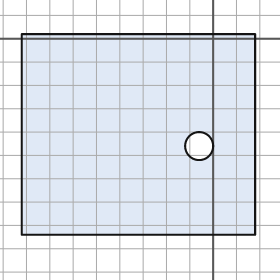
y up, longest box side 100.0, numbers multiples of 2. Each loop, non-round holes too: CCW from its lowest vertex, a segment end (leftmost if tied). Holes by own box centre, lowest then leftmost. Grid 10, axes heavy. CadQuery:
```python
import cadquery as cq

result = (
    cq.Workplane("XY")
    .moveTo(-82.0, -84.0)
    .lineTo(18.0, -84.0)
    .lineTo(18.0, 2.0)
    .lineTo(-82.0, 2.0)
    .close()
    .moveTo(-6.0, -46.0)
    .circle(6.0)
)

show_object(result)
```